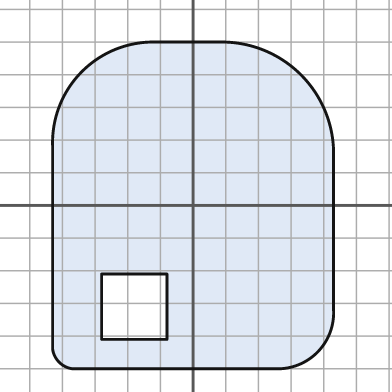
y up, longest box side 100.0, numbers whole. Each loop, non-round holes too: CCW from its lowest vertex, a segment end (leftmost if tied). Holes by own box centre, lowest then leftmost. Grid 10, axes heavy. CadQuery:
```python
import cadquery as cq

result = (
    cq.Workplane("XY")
    .moveTo(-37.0, -50.0)
    .lineTo(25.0, -50.0)
    .threePointArc((38.0, -45.0), (43.0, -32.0))
    .lineTo(43.0, 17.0)
    .threePointArc((33.0, 40.0), (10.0, 50.0))
    .lineTo(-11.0, 50.0)
    .threePointArc((-34.0, 41.0), (-43.0, 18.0))
    .lineTo(-43.0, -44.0)
    .threePointArc((-41.0, -48.0), (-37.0, -50.0))
    .close()
    .moveTo(-28.0, -41.0)
    .lineTo(-8.0, -41.0)
    .lineTo(-8.0, -21.0)
    .lineTo(-28.0, -21.0)
    .close()
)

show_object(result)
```